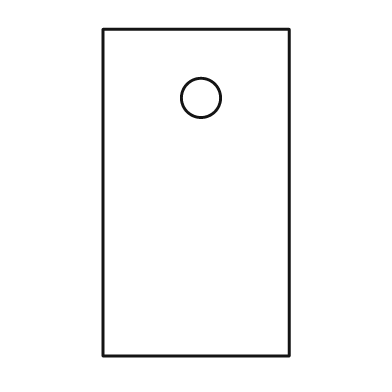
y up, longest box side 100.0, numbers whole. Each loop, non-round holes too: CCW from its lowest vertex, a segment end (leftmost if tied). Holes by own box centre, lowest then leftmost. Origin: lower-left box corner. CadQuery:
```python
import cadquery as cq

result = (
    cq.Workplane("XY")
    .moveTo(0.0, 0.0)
    .lineTo(57.0, 0.0)
    .lineTo(57.0, 100.0)
    .lineTo(0.0, 100.0)
    .close()
    .moveTo(30.0, 79.0)
    .circle(6.0)
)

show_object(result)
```